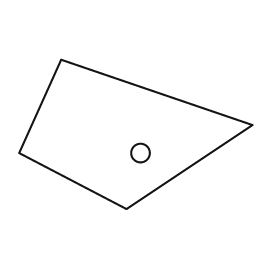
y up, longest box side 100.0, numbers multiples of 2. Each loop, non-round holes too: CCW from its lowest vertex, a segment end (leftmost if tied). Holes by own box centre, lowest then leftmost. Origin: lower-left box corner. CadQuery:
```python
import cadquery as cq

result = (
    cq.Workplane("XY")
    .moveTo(46.0, 0.0)
    .lineTo(100.0, 36.0)
    .lineTo(18.0, 64.0)
    .lineTo(0.0, 24.0)
    .close()
    .moveTo(52.0, 24.0)
    .circle(4.0)
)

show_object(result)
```